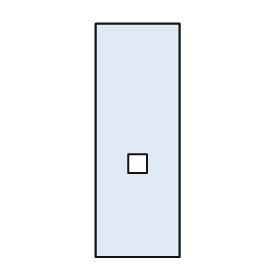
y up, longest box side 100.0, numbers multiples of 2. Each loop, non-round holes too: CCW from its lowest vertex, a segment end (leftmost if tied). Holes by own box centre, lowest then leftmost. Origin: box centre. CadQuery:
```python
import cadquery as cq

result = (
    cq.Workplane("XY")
    .moveTo(-18.0, -50.0)
    .lineTo(18.0, -50.0)
    .lineTo(18.0, 50.0)
    .lineTo(-18.0, 50.0)
    .close()
    .moveTo(-4.0, -14.0)
    .lineTo(4.0, -14.0)
    .lineTo(4.0, -6.0)
    .lineTo(-4.0, -6.0)
    .close()
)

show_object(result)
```